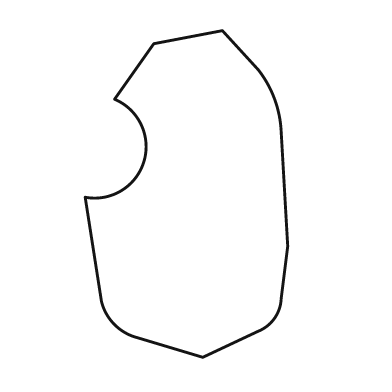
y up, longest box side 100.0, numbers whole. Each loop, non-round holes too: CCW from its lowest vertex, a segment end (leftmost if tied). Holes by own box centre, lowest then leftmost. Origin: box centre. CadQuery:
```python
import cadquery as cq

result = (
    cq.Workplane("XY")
    .moveTo(5.0, -50.0)
    .lineTo(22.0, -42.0)
    .threePointArc((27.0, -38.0), (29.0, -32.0))
    .lineTo(31.0, -16.0)
    .lineTo(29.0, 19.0)
    .threePointArc((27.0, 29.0), (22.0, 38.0))
    .lineTo(11.0, 50.0)
    .lineTo(-10.0, 46.0)
    .lineTo(-22.0, 29.0)
    .threePointArc((-13.0, 10.0), (-31.0, -1.0))
    .lineTo(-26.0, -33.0)
    .threePointArc((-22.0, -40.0), (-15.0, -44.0))
    .close()
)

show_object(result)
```